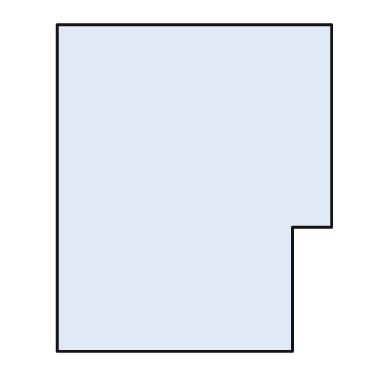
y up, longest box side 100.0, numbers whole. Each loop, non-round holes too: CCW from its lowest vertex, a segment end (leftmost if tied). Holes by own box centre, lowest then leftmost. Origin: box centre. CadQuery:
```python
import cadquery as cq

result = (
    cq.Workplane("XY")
    .moveTo(-42.0, -50.0)
    .lineTo(30.0, -50.0)
    .lineTo(30.0, -12.0)
    .lineTo(42.0, -12.0)
    .lineTo(42.0, 50.0)
    .lineTo(-42.0, 50.0)
    .close()
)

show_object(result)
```